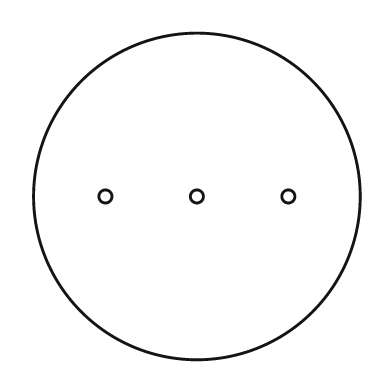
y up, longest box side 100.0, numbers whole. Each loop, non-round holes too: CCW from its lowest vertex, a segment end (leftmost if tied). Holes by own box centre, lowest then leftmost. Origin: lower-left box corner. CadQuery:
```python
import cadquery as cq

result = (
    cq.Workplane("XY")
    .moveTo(50.0, 50.0)
    .circle(50.0)
    .moveTo(22.0, 50.0)
    .circle(2.0)
    .moveTo(50.0, 50.0)
    .circle(2.0)
    .moveTo(78.0, 50.0)
    .circle(2.0)
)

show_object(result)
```